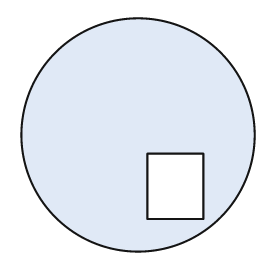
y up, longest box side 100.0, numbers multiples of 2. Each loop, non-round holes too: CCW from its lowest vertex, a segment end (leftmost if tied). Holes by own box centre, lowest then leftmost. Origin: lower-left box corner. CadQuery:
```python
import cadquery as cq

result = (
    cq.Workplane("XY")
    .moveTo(50.0, 50.0)
    .circle(50.0)
    .moveTo(54.0, 14.0)
    .lineTo(78.0, 14.0)
    .lineTo(78.0, 42.0)
    .lineTo(54.0, 42.0)
    .close()
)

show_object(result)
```